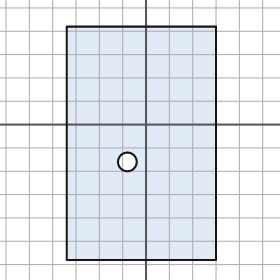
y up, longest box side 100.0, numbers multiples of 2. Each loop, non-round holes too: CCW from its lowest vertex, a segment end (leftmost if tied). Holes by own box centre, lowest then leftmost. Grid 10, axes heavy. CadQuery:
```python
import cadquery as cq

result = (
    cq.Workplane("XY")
    .moveTo(-34.0, -58.0)
    .lineTo(30.0, -58.0)
    .lineTo(30.0, 42.0)
    .lineTo(-34.0, 42.0)
    .close()
    .moveTo(-8.0, -16.0)
    .circle(4.0)
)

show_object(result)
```